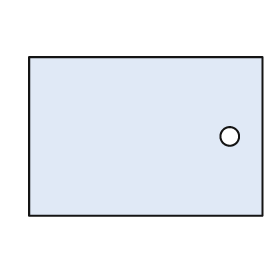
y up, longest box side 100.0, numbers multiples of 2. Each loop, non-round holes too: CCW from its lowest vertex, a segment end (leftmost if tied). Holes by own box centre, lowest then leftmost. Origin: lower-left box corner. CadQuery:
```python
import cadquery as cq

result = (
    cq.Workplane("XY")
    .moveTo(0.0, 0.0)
    .lineTo(100.0, 0.0)
    .lineTo(100.0, 68.0)
    .lineTo(0.0, 68.0)
    .close()
    .moveTo(86.0, 34.0)
    .circle(4.0)
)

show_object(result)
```